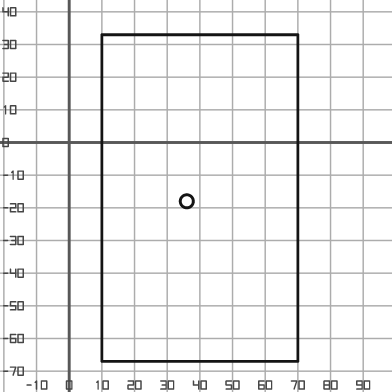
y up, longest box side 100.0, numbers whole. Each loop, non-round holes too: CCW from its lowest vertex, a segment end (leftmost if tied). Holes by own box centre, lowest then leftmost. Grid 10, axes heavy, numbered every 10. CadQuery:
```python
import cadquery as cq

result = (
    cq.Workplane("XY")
    .moveTo(10.0, -67.0)
    .lineTo(70.0, -67.0)
    .lineTo(70.0, 33.0)
    .lineTo(10.0, 33.0)
    .close()
    .moveTo(36.0, -18.0)
    .circle(2.0)
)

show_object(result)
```